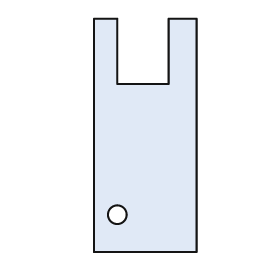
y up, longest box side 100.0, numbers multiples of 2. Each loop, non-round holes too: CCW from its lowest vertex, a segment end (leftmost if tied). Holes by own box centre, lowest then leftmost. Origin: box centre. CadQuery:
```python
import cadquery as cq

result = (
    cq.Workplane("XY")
    .moveTo(-22.0, -50.0)
    .lineTo(22.0, -50.0)
    .lineTo(22.0, 50.0)
    .lineTo(10.0, 50.0)
    .lineTo(10.0, 22.0)
    .lineTo(-12.0, 22.0)
    .lineTo(-12.0, 50.0)
    .lineTo(-22.0, 50.0)
    .close()
    .moveTo(-12.0, -34.0)
    .circle(4.0)
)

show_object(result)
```